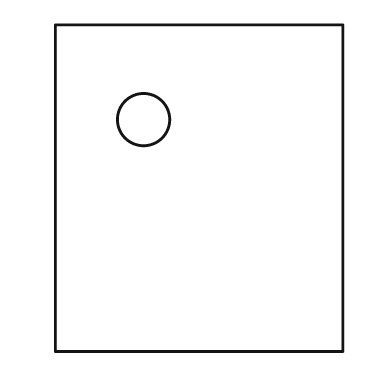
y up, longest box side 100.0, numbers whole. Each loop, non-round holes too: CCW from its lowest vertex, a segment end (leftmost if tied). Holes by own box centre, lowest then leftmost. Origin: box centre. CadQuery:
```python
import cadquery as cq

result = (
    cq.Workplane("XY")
    .moveTo(-44.0, -50.0)
    .lineTo(44.0, -50.0)
    .lineTo(44.0, 50.0)
    .lineTo(-44.0, 50.0)
    .close()
    .moveTo(-17.0, 21.0)
    .circle(8.0)
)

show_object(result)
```